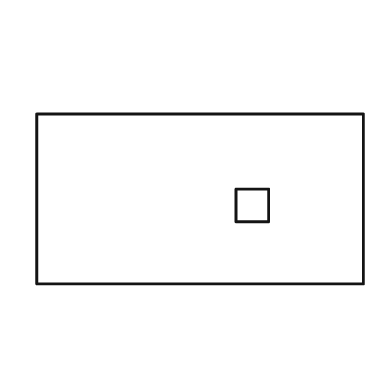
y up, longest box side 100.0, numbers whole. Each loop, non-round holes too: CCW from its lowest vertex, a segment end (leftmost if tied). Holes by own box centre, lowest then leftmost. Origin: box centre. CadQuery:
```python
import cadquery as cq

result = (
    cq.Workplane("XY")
    .moveTo(-50.0, -26.0)
    .lineTo(50.0, -26.0)
    .lineTo(50.0, 26.0)
    .lineTo(-50.0, 26.0)
    .close()
    .moveTo(11.0, -7.0)
    .lineTo(21.0, -7.0)
    .lineTo(21.0, 3.0)
    .lineTo(11.0, 3.0)
    .close()
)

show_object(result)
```